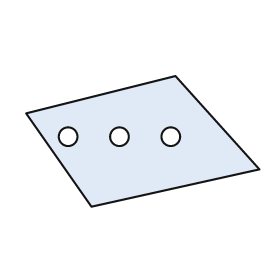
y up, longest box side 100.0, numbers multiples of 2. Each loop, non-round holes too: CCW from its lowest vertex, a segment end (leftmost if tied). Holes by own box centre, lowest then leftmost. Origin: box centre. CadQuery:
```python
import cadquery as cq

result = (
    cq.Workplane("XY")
    .moveTo(-22.0, -28.0)
    .lineTo(50.0, -12.0)
    .lineTo(14.0, 28.0)
    .lineTo(-50.0, 12.0)
    .close()
    .moveTo(-32.0, 2.0)
    .circle(4.0)
    .moveTo(-10.0, 2.0)
    .circle(4.0)
    .moveTo(12.0, 2.0)
    .circle(4.0)
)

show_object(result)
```